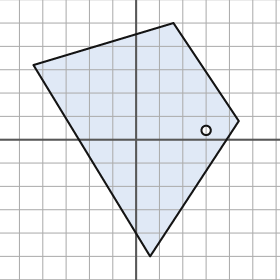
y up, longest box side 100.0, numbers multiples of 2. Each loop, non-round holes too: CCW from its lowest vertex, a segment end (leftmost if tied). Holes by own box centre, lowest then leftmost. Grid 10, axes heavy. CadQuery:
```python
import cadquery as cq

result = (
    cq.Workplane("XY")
    .moveTo(6.0, -50.0)
    .lineTo(44.0, 8.0)
    .lineTo(16.0, 50.0)
    .lineTo(-44.0, 32.0)
    .close()
    .moveTo(30.0, 4.0)
    .circle(2.0)
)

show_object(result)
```